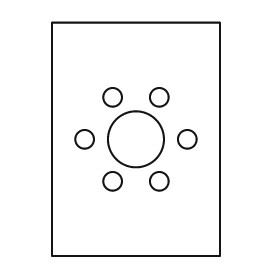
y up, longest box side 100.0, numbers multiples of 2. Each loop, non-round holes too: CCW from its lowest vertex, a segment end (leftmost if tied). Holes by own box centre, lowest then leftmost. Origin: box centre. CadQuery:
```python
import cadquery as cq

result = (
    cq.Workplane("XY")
    .moveTo(-36.0, -50.0)
    .lineTo(36.0, -50.0)
    .lineTo(36.0, 50.0)
    .lineTo(-36.0, 50.0)
    .close()
    .moveTo(-10.0, -18.0)
    .circle(4.0)
    .moveTo(10.0, -18.0)
    .circle(4.0)
    .moveTo(-22.0, 0.0)
    .circle(4.0)
    .moveTo(0.0, 0.0)
    .circle(12.0)
    .moveTo(22.0, 0.0)
    .circle(4.0)
    .moveTo(-10.0, 18.0)
    .circle(4.0)
    .moveTo(10.0, 18.0)
    .circle(4.0)
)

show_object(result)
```